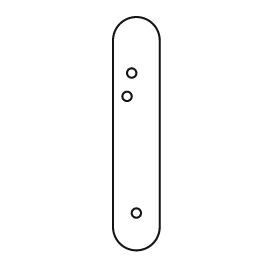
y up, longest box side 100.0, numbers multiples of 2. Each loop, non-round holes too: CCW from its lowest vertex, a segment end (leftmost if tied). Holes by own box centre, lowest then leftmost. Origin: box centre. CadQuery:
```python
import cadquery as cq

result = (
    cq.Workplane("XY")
    .moveTo(-10.0, -40.0)
    .threePointArc((0.0, -50.0), (10.0, -40.0))
    .lineTo(10.0, 40.0)
    .threePointArc((0.0, 50.0), (-10.0, 40.0))
    .close()
    .moveTo(0.0, -34.0)
    .circle(2.0)
    .moveTo(-4.0, 16.0)
    .circle(2.0)
    .moveTo(-2.0, 26.0)
    .circle(2.0)
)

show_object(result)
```